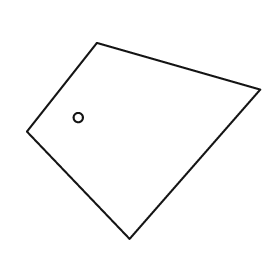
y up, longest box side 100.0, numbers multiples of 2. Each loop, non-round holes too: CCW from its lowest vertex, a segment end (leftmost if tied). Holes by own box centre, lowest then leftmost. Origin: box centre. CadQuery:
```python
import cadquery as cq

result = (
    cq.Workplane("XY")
    .moveTo(-6.0, -42.0)
    .lineTo(50.0, 22.0)
    .lineTo(-20.0, 42.0)
    .lineTo(-50.0, 4.0)
    .close()
    .moveTo(-28.0, 10.0)
    .circle(2.0)
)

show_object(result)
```